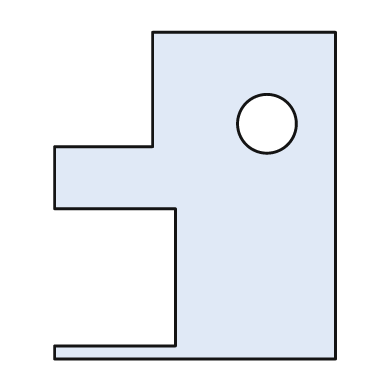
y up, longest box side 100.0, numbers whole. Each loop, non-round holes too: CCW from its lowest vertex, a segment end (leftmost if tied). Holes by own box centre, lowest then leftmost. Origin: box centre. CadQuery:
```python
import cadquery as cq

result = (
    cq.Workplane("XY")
    .moveTo(-43.0, -50.0)
    .lineTo(43.0, -50.0)
    .lineTo(43.0, 50.0)
    .lineTo(-13.0, 50.0)
    .lineTo(-13.0, 15.0)
    .lineTo(-43.0, 15.0)
    .lineTo(-43.0, -4.0)
    .lineTo(-6.0, -4.0)
    .lineTo(-6.0, -46.0)
    .lineTo(-43.0, -46.0)
    .close()
    .moveTo(22.0, 22.0)
    .circle(9.0)
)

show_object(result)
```